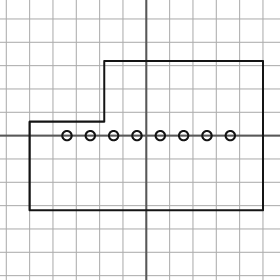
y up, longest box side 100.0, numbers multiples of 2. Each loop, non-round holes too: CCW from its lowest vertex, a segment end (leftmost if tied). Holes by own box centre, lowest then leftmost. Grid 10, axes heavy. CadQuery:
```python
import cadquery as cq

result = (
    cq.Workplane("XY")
    .moveTo(-50.0, -32.0)
    .lineTo(50.0, -32.0)
    .lineTo(50.0, 32.0)
    .lineTo(-18.0, 32.0)
    .lineTo(-18.0, 6.0)
    .lineTo(-50.0, 6.0)
    .close()
    .moveTo(-34.0, 0.0)
    .circle(2.0)
    .moveTo(-24.0, 0.0)
    .circle(2.0)
    .moveTo(-14.0, 0.0)
    .circle(2.0)
    .moveTo(-4.0, 0.0)
    .circle(2.0)
    .moveTo(6.0, 0.0)
    .circle(2.0)
    .moveTo(16.0, 0.0)
    .circle(2.0)
    .moveTo(26.0, 0.0)
    .circle(2.0)
    .moveTo(36.0, 0.0)
    .circle(2.0)
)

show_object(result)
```